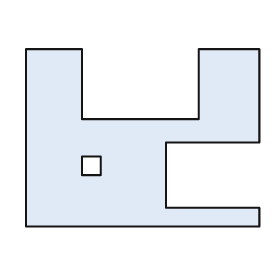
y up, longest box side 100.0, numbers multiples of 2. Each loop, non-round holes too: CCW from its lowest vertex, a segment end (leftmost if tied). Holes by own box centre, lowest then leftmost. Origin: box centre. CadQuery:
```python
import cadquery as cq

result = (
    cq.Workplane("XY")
    .moveTo(-50.0, -38.0)
    .lineTo(50.0, -38.0)
    .lineTo(50.0, -30.0)
    .lineTo(10.0, -30.0)
    .lineTo(10.0, -2.0)
    .lineTo(50.0, -2.0)
    .lineTo(50.0, 38.0)
    .lineTo(24.0, 38.0)
    .lineTo(24.0, 8.0)
    .lineTo(-26.0, 8.0)
    .lineTo(-26.0, 38.0)
    .lineTo(-50.0, 38.0)
    .close()
    .moveTo(-26.0, -16.0)
    .lineTo(-18.0, -16.0)
    .lineTo(-18.0, -8.0)
    .lineTo(-26.0, -8.0)
    .close()
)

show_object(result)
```